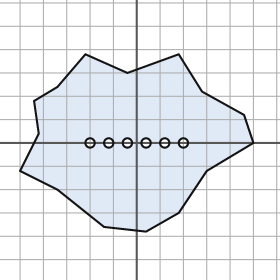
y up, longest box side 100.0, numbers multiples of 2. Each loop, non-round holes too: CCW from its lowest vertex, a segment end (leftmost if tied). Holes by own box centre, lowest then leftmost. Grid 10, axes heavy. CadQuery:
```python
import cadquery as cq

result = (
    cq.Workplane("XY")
    .moveTo(4.0, -38.0)
    .lineTo(18.0, -30.0)
    .lineTo(30.0, -12.0)
    .lineTo(50.0, 0.0)
    .lineTo(46.0, 12.0)
    .lineTo(28.0, 22.0)
    .lineTo(18.0, 38.0)
    .lineTo(-4.0, 30.0)
    .lineTo(-22.0, 38.0)
    .lineTo(-34.0, 24.0)
    .lineTo(-44.0, 18.0)
    .lineTo(-42.0, 4.0)
    .lineTo(-50.0, -12.0)
    .lineTo(-34.0, -20.0)
    .lineTo(-14.0, -36.0)
    .close()
    .moveTo(-20.0, 0.0)
    .circle(2.0)
    .moveTo(-12.0, 0.0)
    .circle(2.0)
    .moveTo(-4.0, 0.0)
    .circle(2.0)
    .moveTo(4.0, 0.0)
    .circle(2.0)
    .moveTo(12.0, 0.0)
    .circle(2.0)
    .moveTo(20.0, 0.0)
    .circle(2.0)
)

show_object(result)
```